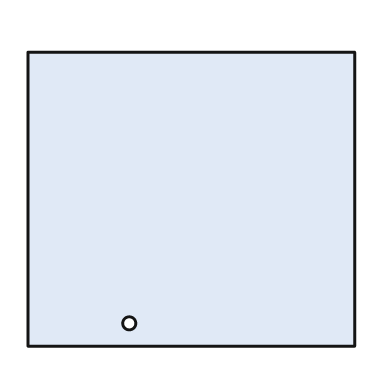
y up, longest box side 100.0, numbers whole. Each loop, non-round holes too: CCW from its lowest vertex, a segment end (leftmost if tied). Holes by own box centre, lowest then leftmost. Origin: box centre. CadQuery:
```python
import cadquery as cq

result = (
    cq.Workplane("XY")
    .moveTo(-50.0, -45.0)
    .lineTo(50.0, -45.0)
    .lineTo(50.0, 45.0)
    .lineTo(-50.0, 45.0)
    .close()
    .moveTo(-19.0, -38.0)
    .circle(2.0)
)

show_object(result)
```